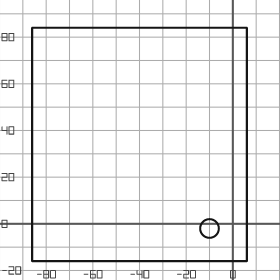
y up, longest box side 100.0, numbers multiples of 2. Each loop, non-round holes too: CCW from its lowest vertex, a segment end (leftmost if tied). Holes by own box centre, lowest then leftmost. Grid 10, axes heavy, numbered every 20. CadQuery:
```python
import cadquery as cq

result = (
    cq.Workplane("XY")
    .moveTo(-86.0, -16.0)
    .lineTo(6.0, -16.0)
    .lineTo(6.0, 84.0)
    .lineTo(-86.0, 84.0)
    .close()
    .moveTo(-10.0, -2.0)
    .circle(4.0)
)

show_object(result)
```